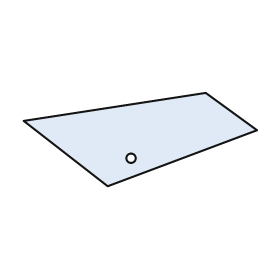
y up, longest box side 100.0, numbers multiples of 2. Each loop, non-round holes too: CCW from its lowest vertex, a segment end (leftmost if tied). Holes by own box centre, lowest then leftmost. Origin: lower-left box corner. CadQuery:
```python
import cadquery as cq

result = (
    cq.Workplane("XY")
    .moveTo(36.0, 0.0)
    .lineTo(100.0, 24.0)
    .lineTo(78.0, 40.0)
    .lineTo(0.0, 28.0)
    .close()
    .moveTo(46.0, 12.0)
    .circle(2.0)
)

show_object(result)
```